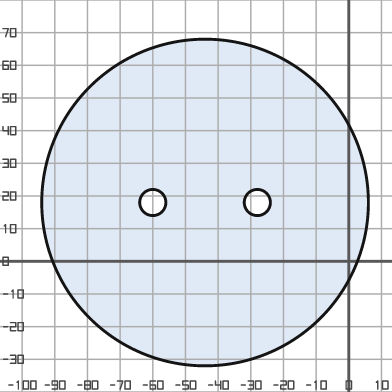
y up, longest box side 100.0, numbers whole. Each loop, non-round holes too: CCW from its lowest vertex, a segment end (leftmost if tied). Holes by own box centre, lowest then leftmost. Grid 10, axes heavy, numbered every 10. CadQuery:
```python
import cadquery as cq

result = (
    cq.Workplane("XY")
    .moveTo(-44.0, 18.0)
    .circle(50.0)
    .moveTo(-60.0, 18.0)
    .circle(4.0)
    .moveTo(-28.0, 18.0)
    .circle(4.0)
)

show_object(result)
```